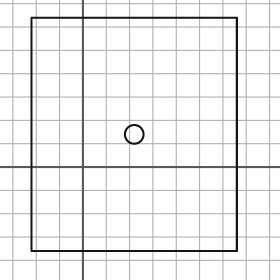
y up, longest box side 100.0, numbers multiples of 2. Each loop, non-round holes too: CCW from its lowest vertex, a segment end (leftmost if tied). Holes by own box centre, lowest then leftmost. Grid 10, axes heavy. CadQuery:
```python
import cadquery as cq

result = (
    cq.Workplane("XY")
    .moveTo(-22.0, -36.0)
    .lineTo(66.0, -36.0)
    .lineTo(66.0, 64.0)
    .lineTo(-22.0, 64.0)
    .close()
    .moveTo(22.0, 14.0)
    .circle(4.0)
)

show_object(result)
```